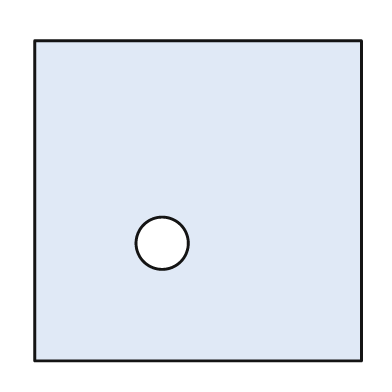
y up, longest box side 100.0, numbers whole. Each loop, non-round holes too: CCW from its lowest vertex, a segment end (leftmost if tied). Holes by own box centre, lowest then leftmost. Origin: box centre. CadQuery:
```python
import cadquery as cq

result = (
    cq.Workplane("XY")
    .moveTo(-50.0, -49.0)
    .lineTo(50.0, -49.0)
    .lineTo(50.0, 49.0)
    .lineTo(-50.0, 49.0)
    .close()
    .moveTo(-11.0, -13.0)
    .circle(8.0)
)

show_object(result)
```